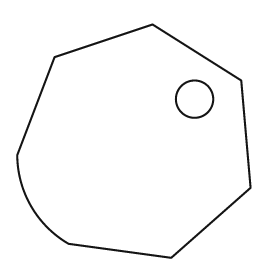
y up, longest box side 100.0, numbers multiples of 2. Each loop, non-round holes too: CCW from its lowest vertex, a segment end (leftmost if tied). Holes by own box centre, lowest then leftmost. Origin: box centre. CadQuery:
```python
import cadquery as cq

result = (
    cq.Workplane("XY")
    .moveTo(16.0, -50.0)
    .lineTo(50.0, -20.0)
    .lineTo(46.0, 26.0)
    .lineTo(8.0, 50.0)
    .lineTo(-34.0, 36.0)
    .lineTo(-50.0, -6.0)
    .threePointArc((-44.0, -28.0), (-28.0, -44.0))
    .close()
    .moveTo(26.0, 18.0)
    .circle(8.0)
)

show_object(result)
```